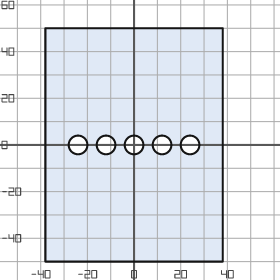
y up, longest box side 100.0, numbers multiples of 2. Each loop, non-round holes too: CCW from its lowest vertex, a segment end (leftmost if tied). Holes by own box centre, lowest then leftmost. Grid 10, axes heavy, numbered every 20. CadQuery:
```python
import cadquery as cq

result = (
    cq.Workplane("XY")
    .moveTo(-38.0, -50.0)
    .lineTo(38.0, -50.0)
    .lineTo(38.0, 50.0)
    .lineTo(-38.0, 50.0)
    .close()
    .moveTo(-24.0, 0.0)
    .circle(4.0)
    .moveTo(-12.0, 0.0)
    .circle(4.0)
    .moveTo(0.0, 0.0)
    .circle(4.0)
    .moveTo(12.0, 0.0)
    .circle(4.0)
    .moveTo(24.0, 0.0)
    .circle(4.0)
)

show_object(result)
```